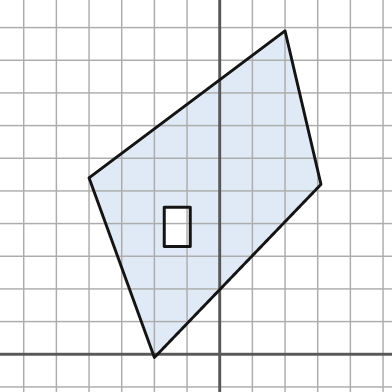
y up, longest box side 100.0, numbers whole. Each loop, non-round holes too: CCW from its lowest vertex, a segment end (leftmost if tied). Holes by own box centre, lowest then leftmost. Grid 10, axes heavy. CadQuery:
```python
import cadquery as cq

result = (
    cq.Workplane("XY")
    .moveTo(-20.0, -1.0)
    .lineTo(31.0, 52.0)
    .lineTo(20.0, 99.0)
    .lineTo(-40.0, 54.0)
    .close()
    .moveTo(-17.0, 33.0)
    .lineTo(-9.0, 33.0)
    .lineTo(-9.0, 45.0)
    .lineTo(-17.0, 45.0)
    .close()
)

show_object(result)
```